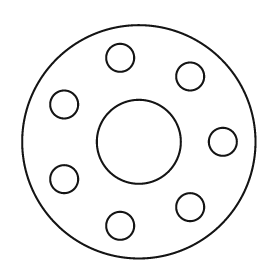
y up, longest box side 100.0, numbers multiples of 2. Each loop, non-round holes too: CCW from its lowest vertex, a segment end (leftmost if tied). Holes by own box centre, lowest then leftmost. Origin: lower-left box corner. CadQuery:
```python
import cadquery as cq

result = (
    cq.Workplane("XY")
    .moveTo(50.0, 50.0)
    .circle(50.0)
    .moveTo(42.0, 14.0)
    .circle(6.0)
    .moveTo(72.0, 22.0)
    .circle(6.0)
    .moveTo(18.0, 34.0)
    .circle(6.0)
    .moveTo(50.0, 50.0)
    .circle(18.0)
    .moveTo(86.0, 50.0)
    .circle(6.0)
    .moveTo(18.0, 66.0)
    .circle(6.0)
    .moveTo(72.0, 78.0)
    .circle(6.0)
    .moveTo(42.0, 86.0)
    .circle(6.0)
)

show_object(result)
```